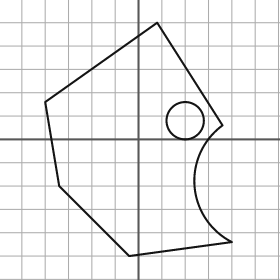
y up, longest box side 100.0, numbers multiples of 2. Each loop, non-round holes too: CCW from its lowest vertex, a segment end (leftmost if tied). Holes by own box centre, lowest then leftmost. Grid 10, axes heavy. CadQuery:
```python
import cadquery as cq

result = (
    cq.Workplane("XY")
    .moveTo(-4.0, -50.0)
    .lineTo(40.0, -44.0)
    .threePointArc((24.0, -20.0), (36.0, 6.0))
    .lineTo(8.0, 50.0)
    .lineTo(-40.0, 16.0)
    .lineTo(-34.0, -20.0)
    .close()
    .moveTo(20.0, 8.0)
    .circle(8.0)
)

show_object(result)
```